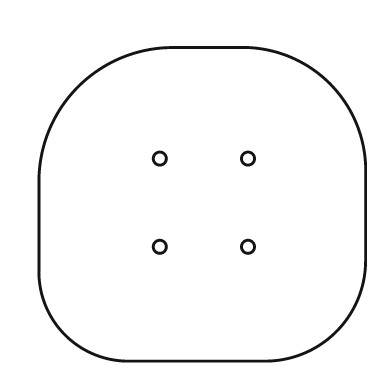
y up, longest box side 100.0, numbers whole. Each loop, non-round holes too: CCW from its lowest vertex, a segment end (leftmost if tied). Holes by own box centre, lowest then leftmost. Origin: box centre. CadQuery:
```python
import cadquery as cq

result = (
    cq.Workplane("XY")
    .moveTo(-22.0, -48.0)
    .lineTo(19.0, -48.0)
    .threePointArc((41.0, -39.0), (50.0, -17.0))
    .lineTo(50.0, 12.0)
    .threePointArc((39.0, 37.0), (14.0, 48.0))
    .lineTo(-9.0, 48.0)
    .threePointArc((-38.0, 36.0), (-50.0, 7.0))
    .lineTo(-50.0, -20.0)
    .threePointArc((-42.0, -40.0), (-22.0, -48.0))
    .close()
    .moveTo(-13.0, -13.0)
    .circle(2.0)
    .moveTo(14.0, -13.0)
    .circle(2.0)
    .moveTo(-13.0, 14.0)
    .circle(2.0)
    .moveTo(14.0, 14.0)
    .circle(2.0)
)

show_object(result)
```